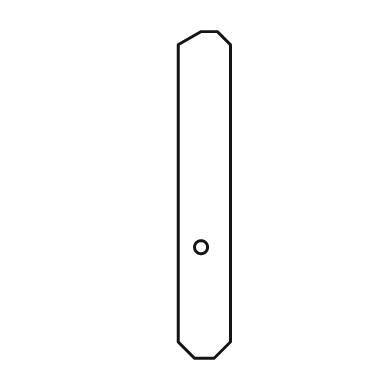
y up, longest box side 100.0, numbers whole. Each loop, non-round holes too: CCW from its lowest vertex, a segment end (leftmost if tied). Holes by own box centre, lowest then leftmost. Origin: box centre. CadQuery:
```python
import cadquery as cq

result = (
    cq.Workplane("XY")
    .moveTo(-3.0, -50.0)
    .lineTo(3.0, -50.0)
    .lineTo(8.0, -45.0)
    .lineTo(8.0, 46.0)
    .lineTo(4.0, 50.0)
    .lineTo(-1.0, 50.0)
    .lineTo(-8.0, 46.0)
    .lineTo(-8.0, -45.0)
    .close()
    .moveTo(-1.0, -16.0)
    .circle(2.0)
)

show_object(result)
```